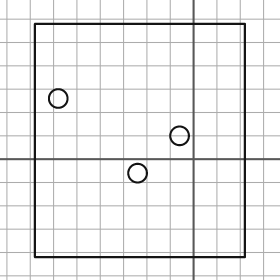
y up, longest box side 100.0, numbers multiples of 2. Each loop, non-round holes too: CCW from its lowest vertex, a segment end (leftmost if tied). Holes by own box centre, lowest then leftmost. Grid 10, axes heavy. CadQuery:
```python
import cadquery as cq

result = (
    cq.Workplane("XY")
    .moveTo(-68.0, -42.0)
    .lineTo(22.0, -42.0)
    .lineTo(22.0, 58.0)
    .lineTo(-68.0, 58.0)
    .close()
    .moveTo(-24.0, -6.0)
    .circle(4.0)
    .moveTo(-6.0, 10.0)
    .circle(4.0)
    .moveTo(-58.0, 26.0)
    .circle(4.0)
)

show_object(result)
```